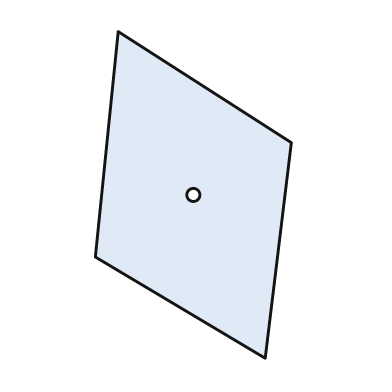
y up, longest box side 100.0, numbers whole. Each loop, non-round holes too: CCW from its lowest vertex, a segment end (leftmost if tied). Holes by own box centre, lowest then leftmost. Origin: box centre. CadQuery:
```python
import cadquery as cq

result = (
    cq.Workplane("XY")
    .moveTo(22.0, -50.0)
    .lineTo(30.0, 16.0)
    .lineTo(-23.0, 50.0)
    .lineTo(-30.0, -19.0)
    .close()
    .moveTo(0.0, 0.0)
    .circle(2.0)
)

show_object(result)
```